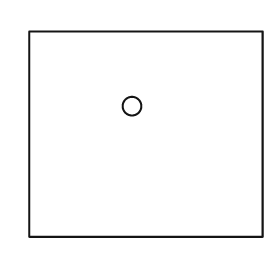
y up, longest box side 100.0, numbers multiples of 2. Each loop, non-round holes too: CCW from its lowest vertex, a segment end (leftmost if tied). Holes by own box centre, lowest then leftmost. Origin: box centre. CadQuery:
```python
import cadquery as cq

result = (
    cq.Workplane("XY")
    .moveTo(-50.0, -44.0)
    .lineTo(50.0, -44.0)
    .lineTo(50.0, 44.0)
    .lineTo(-50.0, 44.0)
    .close()
    .moveTo(-6.0, 12.0)
    .circle(4.0)
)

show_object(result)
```